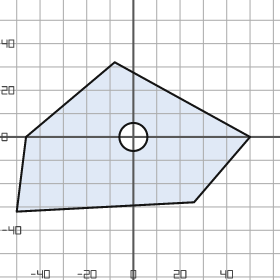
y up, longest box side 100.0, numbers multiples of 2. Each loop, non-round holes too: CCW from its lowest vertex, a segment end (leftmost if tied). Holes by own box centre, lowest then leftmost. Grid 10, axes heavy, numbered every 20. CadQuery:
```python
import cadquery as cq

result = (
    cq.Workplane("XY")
    .moveTo(-50.0, -32.0)
    .lineTo(26.0, -28.0)
    .lineTo(50.0, 0.0)
    .lineTo(-8.0, 32.0)
    .lineTo(-46.0, 0.0)
    .close()
    .moveTo(0.0, 0.0)
    .circle(6.0)
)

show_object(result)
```